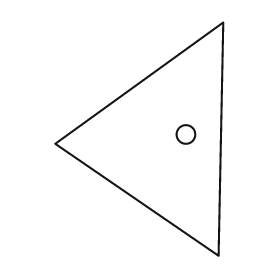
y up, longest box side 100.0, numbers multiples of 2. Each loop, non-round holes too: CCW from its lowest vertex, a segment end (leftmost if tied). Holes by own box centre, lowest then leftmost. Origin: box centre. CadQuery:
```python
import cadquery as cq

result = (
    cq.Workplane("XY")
    .moveTo(34.0, -50.0)
    .lineTo(36.0, 50.0)
    .lineTo(-36.0, -2.0)
    .close()
    .moveTo(20.0, 2.0)
    .circle(4.0)
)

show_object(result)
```